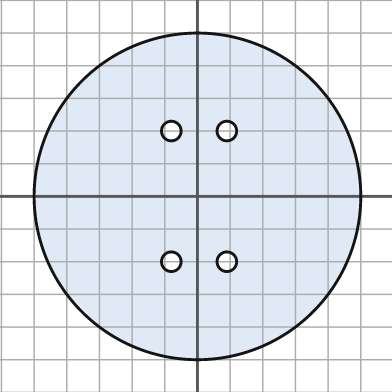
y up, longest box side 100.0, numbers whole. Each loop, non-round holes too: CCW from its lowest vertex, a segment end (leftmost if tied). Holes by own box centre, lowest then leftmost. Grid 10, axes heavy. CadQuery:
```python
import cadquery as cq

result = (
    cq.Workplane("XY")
    .moveTo(0.0, 0.0)
    .circle(50.0)
    .moveTo(-8.0, -20.0)
    .circle(3.0)
    .moveTo(9.0, -20.0)
    .circle(3.0)
    .moveTo(-8.0, 20.0)
    .circle(3.0)
    .moveTo(9.0, 20.0)
    .circle(3.0)
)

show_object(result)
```